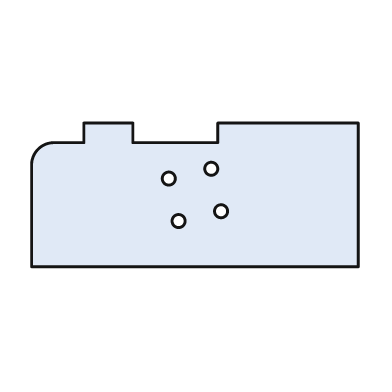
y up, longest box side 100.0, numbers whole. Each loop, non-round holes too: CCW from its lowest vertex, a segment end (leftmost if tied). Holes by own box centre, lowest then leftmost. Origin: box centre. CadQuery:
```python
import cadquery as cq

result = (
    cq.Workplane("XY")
    .moveTo(-50.0, -22.0)
    .lineTo(50.0, -22.0)
    .lineTo(50.0, 22.0)
    .lineTo(7.0, 22.0)
    .lineTo(7.0, 16.0)
    .lineTo(-19.0, 16.0)
    .lineTo(-19.0, 22.0)
    .lineTo(-34.0, 22.0)
    .lineTo(-34.0, 16.0)
    .lineTo(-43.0, 16.0)
    .threePointArc((-48.0, 14.0), (-50.0, 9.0))
    .close()
    .moveTo(-5.0, -8.0)
    .circle(2.0)
    .moveTo(8.0, -5.0)
    .circle(2.0)
    .moveTo(-8.0, 5.0)
    .circle(2.0)
    .moveTo(5.0, 8.0)
    .circle(2.0)
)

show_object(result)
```